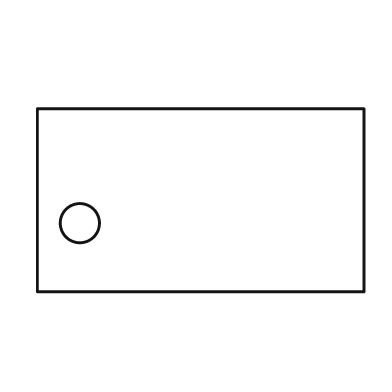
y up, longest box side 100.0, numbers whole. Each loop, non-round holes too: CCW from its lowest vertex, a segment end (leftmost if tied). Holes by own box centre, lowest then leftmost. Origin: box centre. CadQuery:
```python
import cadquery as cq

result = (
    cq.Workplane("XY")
    .moveTo(-50.0, -28.0)
    .lineTo(50.0, -28.0)
    .lineTo(50.0, 28.0)
    .lineTo(-50.0, 28.0)
    .close()
    .moveTo(-37.0, -7.0)
    .circle(6.0)
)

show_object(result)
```